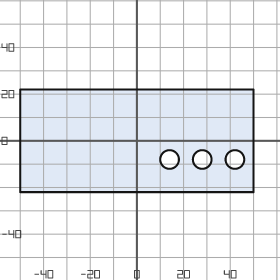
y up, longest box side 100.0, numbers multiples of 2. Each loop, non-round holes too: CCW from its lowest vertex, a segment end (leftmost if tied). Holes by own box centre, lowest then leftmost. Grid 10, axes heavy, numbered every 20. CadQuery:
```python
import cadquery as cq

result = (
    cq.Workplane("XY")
    .moveTo(-50.0, -22.0)
    .lineTo(50.0, -22.0)
    .lineTo(50.0, 22.0)
    .lineTo(-50.0, 22.0)
    .close()
    .moveTo(14.0, -8.0)
    .circle(4.0)
    .moveTo(28.0, -8.0)
    .circle(4.0)
    .moveTo(42.0, -8.0)
    .circle(4.0)
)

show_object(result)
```